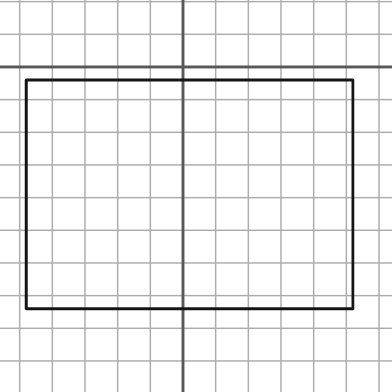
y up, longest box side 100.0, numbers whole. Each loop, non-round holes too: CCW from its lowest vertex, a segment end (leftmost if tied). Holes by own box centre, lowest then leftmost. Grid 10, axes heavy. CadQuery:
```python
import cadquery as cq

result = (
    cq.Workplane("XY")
    .moveTo(-48.0, -74.0)
    .lineTo(52.0, -74.0)
    .lineTo(52.0, -4.0)
    .lineTo(-48.0, -4.0)
    .close()
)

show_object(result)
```